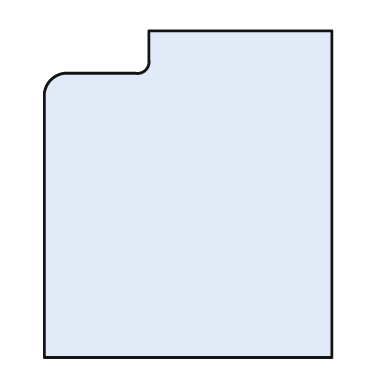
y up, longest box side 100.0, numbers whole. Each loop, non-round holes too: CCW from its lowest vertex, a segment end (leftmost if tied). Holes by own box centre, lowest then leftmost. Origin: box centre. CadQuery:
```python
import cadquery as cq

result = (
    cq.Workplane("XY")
    .moveTo(-44.0, -50.0)
    .lineTo(44.0, -50.0)
    .lineTo(44.0, 50.0)
    .lineTo(-12.0, 50.0)
    .lineTo(-12.0, 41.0)
    .threePointArc((-13.0, 38.0), (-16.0, 37.0))
    .lineTo(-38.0, 37.0)
    .threePointArc((-42.0, 35.0), (-44.0, 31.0))
    .close()
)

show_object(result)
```